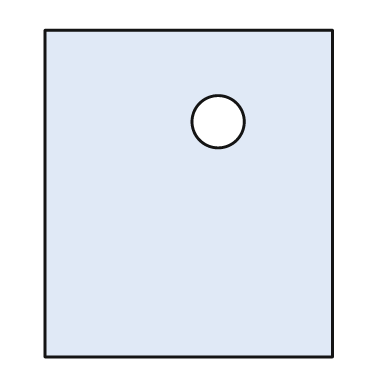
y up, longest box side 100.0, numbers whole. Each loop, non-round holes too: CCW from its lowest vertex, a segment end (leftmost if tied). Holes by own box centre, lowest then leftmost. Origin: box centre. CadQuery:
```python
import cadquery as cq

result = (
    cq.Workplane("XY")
    .moveTo(-44.0, -50.0)
    .lineTo(44.0, -50.0)
    .lineTo(44.0, 50.0)
    .lineTo(-44.0, 50.0)
    .close()
    .moveTo(9.0, 22.0)
    .circle(8.0)
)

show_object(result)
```